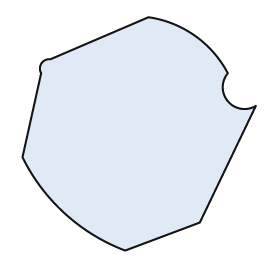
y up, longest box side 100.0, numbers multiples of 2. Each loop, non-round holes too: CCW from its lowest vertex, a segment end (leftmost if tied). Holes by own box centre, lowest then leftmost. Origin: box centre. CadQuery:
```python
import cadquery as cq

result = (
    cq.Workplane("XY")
    .moveTo(-6.0, -50.0)
    .lineTo(26.0, -38.0)
    .lineTo(50.0, 12.0)
    .threePointArc((38.0, 14.0), (38.0, 26.0))
    .threePointArc((24.0, 42.0), (4.0, 50.0))
    .lineTo(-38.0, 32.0)
    .threePointArc((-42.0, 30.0), (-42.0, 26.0))
    .lineTo(-50.0, -10.0)
    .threePointArc((-32.0, -34.0), (-6.0, -50.0))
    .close()
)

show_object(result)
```